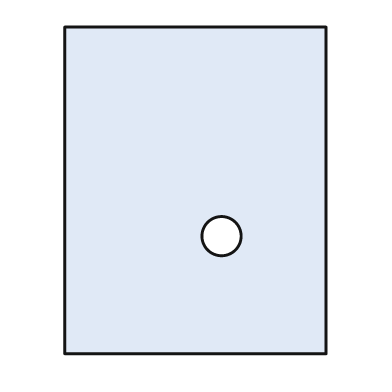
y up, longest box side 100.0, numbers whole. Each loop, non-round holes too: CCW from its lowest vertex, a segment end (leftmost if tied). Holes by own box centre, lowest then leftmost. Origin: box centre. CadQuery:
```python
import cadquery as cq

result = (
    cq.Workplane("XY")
    .moveTo(-40.0, -50.0)
    .lineTo(40.0, -50.0)
    .lineTo(40.0, 50.0)
    .lineTo(-40.0, 50.0)
    .close()
    .moveTo(8.0, -14.0)
    .circle(6.0)
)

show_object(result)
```